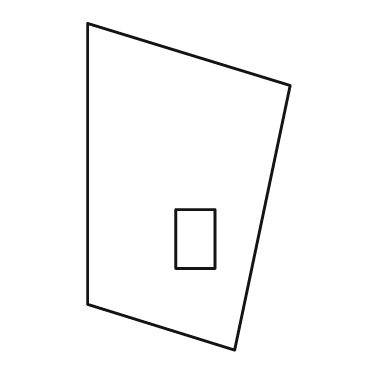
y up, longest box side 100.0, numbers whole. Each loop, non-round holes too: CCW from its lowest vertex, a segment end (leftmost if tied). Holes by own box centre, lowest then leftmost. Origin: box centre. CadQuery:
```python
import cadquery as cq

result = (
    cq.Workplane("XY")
    .moveTo(14.0, -50.0)
    .lineTo(31.0, 31.0)
    .lineTo(-31.0, 50.0)
    .lineTo(-31.0, -36.0)
    .close()
    .moveTo(-4.0, -25.0)
    .lineTo(8.0, -25.0)
    .lineTo(8.0, -7.0)
    .lineTo(-4.0, -7.0)
    .close()
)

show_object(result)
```